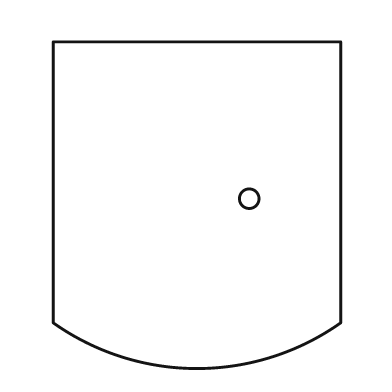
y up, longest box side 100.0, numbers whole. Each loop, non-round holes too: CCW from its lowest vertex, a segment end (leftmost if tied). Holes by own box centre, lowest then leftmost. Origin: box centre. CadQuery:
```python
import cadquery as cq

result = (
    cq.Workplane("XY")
    .moveTo(-44.0, -36.0)
    .threePointArc((0.0, -50.0), (44.0, -36.0))
    .lineTo(44.0, 50.0)
    .lineTo(-44.0, 50.0)
    .close()
    .moveTo(16.0, 2.0)
    .circle(3.0)
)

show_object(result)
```